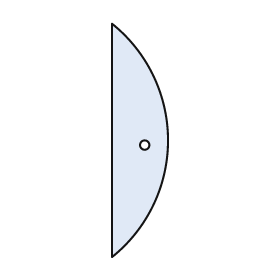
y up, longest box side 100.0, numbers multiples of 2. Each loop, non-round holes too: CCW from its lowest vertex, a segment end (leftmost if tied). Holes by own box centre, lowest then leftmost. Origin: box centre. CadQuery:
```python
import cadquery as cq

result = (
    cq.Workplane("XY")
    .moveTo(-12.0, -50.0)
    .threePointArc((12.0, 0.0), (-12.0, 50.0))
    .close()
    .moveTo(2.0, -2.0)
    .circle(2.0)
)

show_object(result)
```